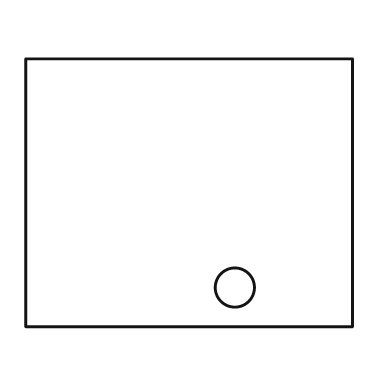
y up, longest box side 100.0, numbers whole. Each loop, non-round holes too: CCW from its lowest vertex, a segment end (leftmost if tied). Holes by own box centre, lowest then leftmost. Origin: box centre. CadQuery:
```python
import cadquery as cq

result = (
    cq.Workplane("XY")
    .moveTo(-50.0, -41.0)
    .lineTo(50.0, -41.0)
    .lineTo(50.0, 41.0)
    .lineTo(-50.0, 41.0)
    .close()
    .moveTo(14.0, -29.0)
    .circle(6.0)
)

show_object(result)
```